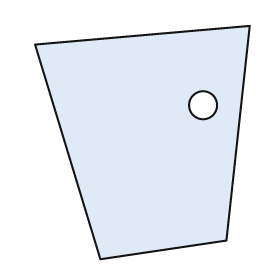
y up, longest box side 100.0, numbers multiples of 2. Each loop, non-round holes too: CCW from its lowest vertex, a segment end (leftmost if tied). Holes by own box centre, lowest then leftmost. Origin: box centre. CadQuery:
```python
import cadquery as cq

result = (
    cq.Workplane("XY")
    .moveTo(-18.0, -50.0)
    .lineTo(36.0, -42.0)
    .lineTo(46.0, 50.0)
    .lineTo(-46.0, 42.0)
    .close()
    .moveTo(26.0, 16.0)
    .circle(6.0)
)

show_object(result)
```